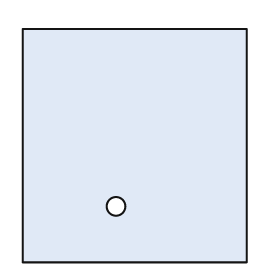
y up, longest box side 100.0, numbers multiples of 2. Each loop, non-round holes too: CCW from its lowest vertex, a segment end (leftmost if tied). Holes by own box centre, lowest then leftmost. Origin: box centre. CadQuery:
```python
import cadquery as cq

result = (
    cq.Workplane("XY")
    .moveTo(-48.0, -50.0)
    .lineTo(48.0, -50.0)
    .lineTo(48.0, 50.0)
    .lineTo(-48.0, 50.0)
    .close()
    .moveTo(-8.0, -26.0)
    .circle(4.0)
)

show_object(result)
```